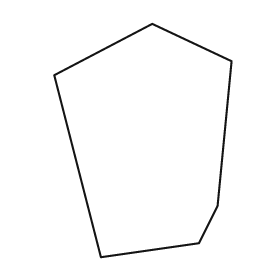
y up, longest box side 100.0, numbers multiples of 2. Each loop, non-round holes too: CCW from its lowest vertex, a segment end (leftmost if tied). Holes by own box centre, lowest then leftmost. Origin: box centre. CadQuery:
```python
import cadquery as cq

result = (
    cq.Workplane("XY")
    .moveTo(-18.0, -50.0)
    .lineTo(24.0, -44.0)
    .lineTo(32.0, -28.0)
    .lineTo(38.0, 34.0)
    .lineTo(4.0, 50.0)
    .lineTo(-38.0, 28.0)
    .close()
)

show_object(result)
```